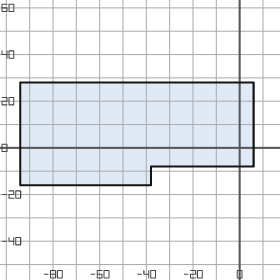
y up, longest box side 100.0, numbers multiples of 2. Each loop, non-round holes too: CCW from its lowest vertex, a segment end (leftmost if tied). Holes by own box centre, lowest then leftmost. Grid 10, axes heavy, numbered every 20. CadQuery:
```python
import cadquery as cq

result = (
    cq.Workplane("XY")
    .moveTo(-94.0, -16.0)
    .lineTo(-38.0, -16.0)
    .lineTo(-38.0, -8.0)
    .lineTo(6.0, -8.0)
    .lineTo(6.0, 28.0)
    .lineTo(-94.0, 28.0)
    .close()
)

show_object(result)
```